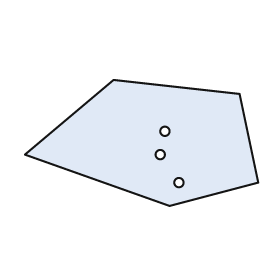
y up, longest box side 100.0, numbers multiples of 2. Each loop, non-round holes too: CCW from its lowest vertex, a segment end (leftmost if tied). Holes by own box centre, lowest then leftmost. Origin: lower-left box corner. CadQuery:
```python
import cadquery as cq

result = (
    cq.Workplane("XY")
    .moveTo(62.0, 0.0)
    .lineTo(100.0, 10.0)
    .lineTo(92.0, 48.0)
    .lineTo(38.0, 54.0)
    .lineTo(0.0, 22.0)
    .close()
    .moveTo(66.0, 10.0)
    .circle(2.0)
    .moveTo(58.0, 22.0)
    .circle(2.0)
    .moveTo(60.0, 32.0)
    .circle(2.0)
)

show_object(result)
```